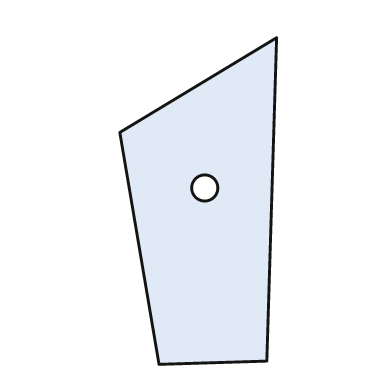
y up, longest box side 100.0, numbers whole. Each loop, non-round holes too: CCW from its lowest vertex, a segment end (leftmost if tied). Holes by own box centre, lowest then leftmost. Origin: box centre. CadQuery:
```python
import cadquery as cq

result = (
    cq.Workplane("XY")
    .moveTo(-12.0, -50.0)
    .lineTo(21.0, -49.0)
    .lineTo(24.0, 50.0)
    .lineTo(-24.0, 21.0)
    .close()
    .moveTo(2.0, 4.0)
    .circle(4.0)
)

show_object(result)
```